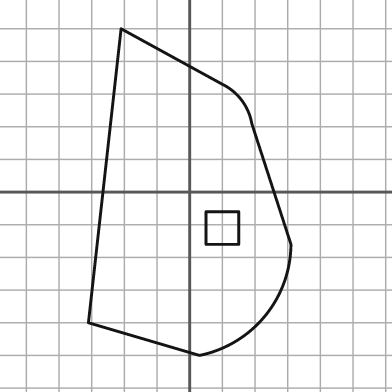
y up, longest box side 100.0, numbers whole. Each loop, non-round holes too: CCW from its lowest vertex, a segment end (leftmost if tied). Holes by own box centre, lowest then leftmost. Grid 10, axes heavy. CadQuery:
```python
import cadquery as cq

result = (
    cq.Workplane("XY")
    .moveTo(3.0, -50.0)
    .threePointArc((23.0, -38.0), (31.0, -16.0))
    .lineTo(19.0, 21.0)
    .threePointArc((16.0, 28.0), (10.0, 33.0))
    .lineTo(-21.0, 50.0)
    .lineTo(-31.0, -40.0)
    .close()
    .moveTo(5.0, -16.0)
    .lineTo(15.0, -16.0)
    .lineTo(15.0, -6.0)
    .lineTo(5.0, -6.0)
    .close()
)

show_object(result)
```